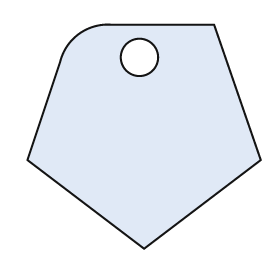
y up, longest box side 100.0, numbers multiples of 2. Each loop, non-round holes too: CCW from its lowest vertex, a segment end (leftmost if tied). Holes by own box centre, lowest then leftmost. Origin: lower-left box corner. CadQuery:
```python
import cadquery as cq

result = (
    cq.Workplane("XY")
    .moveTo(50.0, 0.0)
    .lineTo(100.0, 38.0)
    .lineTo(80.0, 96.0)
    .lineTo(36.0, 96.0)
    .threePointArc((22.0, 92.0), (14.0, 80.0))
    .lineTo(0.0, 38.0)
    .close()
    .moveTo(48.0, 82.0)
    .circle(8.0)
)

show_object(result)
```